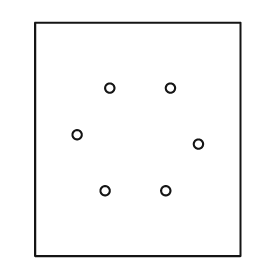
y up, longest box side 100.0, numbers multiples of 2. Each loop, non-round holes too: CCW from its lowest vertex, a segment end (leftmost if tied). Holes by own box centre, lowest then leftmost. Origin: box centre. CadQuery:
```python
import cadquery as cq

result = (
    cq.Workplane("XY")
    .moveTo(-44.0, -50.0)
    .lineTo(44.0, -50.0)
    .lineTo(44.0, 50.0)
    .lineTo(-44.0, 50.0)
    .close()
    .moveTo(-14.0, -22.0)
    .circle(2.0)
    .moveTo(12.0, -22.0)
    .circle(2.0)
    .moveTo(26.0, -2.0)
    .circle(2.0)
    .moveTo(-26.0, 2.0)
    .circle(2.0)
    .moveTo(-12.0, 22.0)
    .circle(2.0)
    .moveTo(14.0, 22.0)
    .circle(2.0)
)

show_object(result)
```